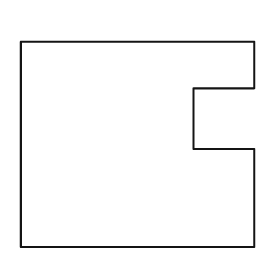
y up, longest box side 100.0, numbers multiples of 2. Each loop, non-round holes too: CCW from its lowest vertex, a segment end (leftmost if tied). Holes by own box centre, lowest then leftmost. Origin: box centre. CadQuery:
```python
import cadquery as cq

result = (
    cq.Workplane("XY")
    .moveTo(-50.0, -44.0)
    .lineTo(50.0, -44.0)
    .lineTo(50.0, -2.0)
    .lineTo(24.0, -2.0)
    .lineTo(24.0, 24.0)
    .lineTo(50.0, 24.0)
    .lineTo(50.0, 44.0)
    .lineTo(-50.0, 44.0)
    .close()
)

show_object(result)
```